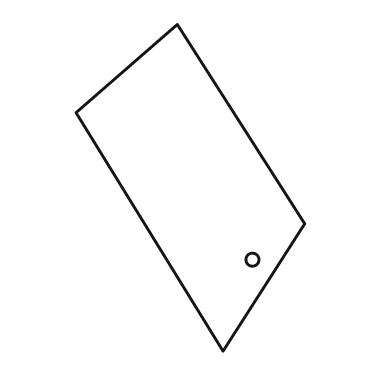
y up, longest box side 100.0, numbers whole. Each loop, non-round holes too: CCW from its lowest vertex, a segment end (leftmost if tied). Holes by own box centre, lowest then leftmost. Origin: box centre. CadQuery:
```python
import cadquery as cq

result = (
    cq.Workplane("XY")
    .moveTo(10.0, -50.0)
    .lineTo(35.0, -11.0)
    .lineTo(-4.0, 50.0)
    .lineTo(-35.0, 23.0)
    .close()
    .moveTo(19.0, -22.0)
    .circle(2.0)
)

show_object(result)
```